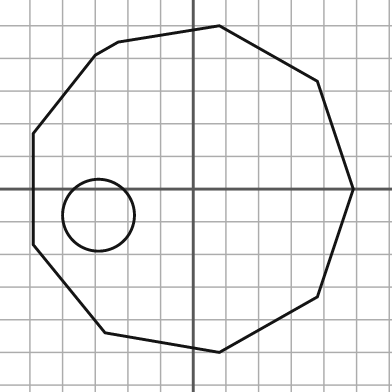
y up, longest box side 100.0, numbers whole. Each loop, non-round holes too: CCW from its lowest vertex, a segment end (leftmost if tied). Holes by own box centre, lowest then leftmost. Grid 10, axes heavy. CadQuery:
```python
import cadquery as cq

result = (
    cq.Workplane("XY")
    .moveTo(8.0, -50.0)
    .lineTo(38.0, -33.0)
    .lineTo(49.0, 0.0)
    .lineTo(38.0, 33.0)
    .lineTo(8.0, 50.0)
    .lineTo(-23.0, 45.0)
    .lineTo(-30.0, 41.0)
    .lineTo(-49.0, 17.0)
    .lineTo(-49.0, -17.0)
    .lineTo(-27.0, -44.0)
    .close()
    .moveTo(-29.0, -8.0)
    .circle(11.0)
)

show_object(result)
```